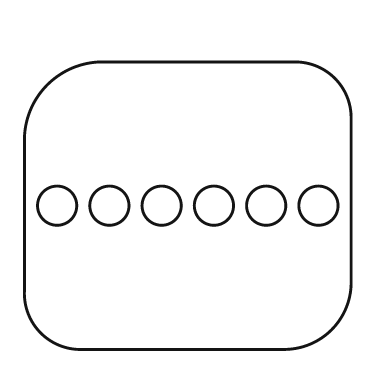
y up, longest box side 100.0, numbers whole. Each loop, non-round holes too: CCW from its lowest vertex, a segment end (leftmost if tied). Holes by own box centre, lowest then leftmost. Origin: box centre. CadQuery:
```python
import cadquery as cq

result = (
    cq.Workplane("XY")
    .moveTo(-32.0, -44.0)
    .lineTo(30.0, -44.0)
    .threePointArc((44.0, -38.0), (50.0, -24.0))
    .lineTo(50.0, 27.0)
    .threePointArc((45.0, 39.0), (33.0, 44.0))
    .lineTo(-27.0, 44.0)
    .threePointArc((-43.0, 37.0), (-50.0, 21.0))
    .lineTo(-50.0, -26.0)
    .threePointArc((-45.0, -39.0), (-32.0, -44.0))
    .close()
    .moveTo(-40.0, 0.0)
    .circle(6.0)
    .moveTo(-24.0, 0.0)
    .circle(6.0)
    .moveTo(-8.0, 0.0)
    .circle(6.0)
    .moveTo(8.0, 0.0)
    .circle(6.0)
    .moveTo(24.0, 0.0)
    .circle(6.0)
    .moveTo(40.0, 0.0)
    .circle(6.0)
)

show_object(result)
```